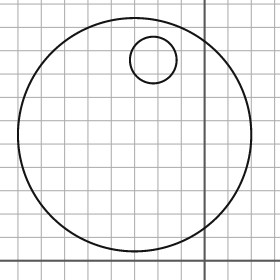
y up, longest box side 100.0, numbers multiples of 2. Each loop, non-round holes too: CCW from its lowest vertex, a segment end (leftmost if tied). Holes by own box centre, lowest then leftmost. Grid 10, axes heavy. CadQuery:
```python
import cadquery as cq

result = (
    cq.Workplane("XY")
    .moveTo(-30.0, 54.0)
    .circle(50.0)
    .moveTo(-22.0, 86.0)
    .circle(10.0)
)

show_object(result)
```